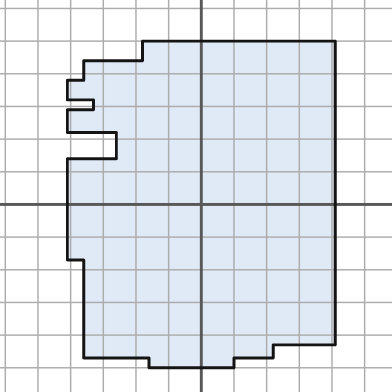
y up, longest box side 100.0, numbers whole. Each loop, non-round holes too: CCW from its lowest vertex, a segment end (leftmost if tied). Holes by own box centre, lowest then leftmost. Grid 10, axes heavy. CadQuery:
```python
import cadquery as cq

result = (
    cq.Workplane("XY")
    .moveTo(-16.0, -50.0)
    .lineTo(10.0, -50.0)
    .lineTo(10.0, -47.0)
    .lineTo(22.0, -47.0)
    .lineTo(22.0, -43.0)
    .lineTo(41.0, -43.0)
    .lineTo(41.0, 50.0)
    .lineTo(-18.0, 50.0)
    .lineTo(-18.0, 44.0)
    .lineTo(-36.0, 44.0)
    .lineTo(-36.0, 38.0)
    .lineTo(-41.0, 38.0)
    .lineTo(-41.0, 32.0)
    .lineTo(-33.0, 32.0)
    .lineTo(-33.0, 29.0)
    .lineTo(-41.0, 29.0)
    .lineTo(-41.0, 22.0)
    .lineTo(-26.0, 22.0)
    .lineTo(-26.0, 14.0)
    .lineTo(-41.0, 14.0)
    .lineTo(-41.0, -17.0)
    .lineTo(-36.0, -17.0)
    .lineTo(-36.0, -47.0)
    .lineTo(-16.0, -47.0)
    .close()
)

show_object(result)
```